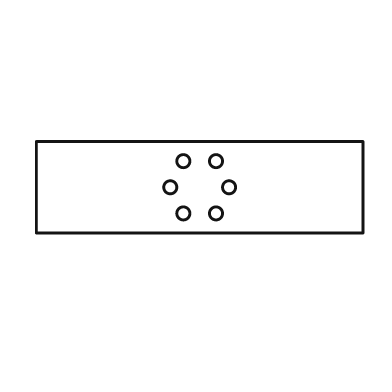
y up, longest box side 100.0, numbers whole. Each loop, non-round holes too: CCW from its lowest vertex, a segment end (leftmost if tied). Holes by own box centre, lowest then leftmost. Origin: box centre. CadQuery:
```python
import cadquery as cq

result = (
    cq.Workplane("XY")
    .moveTo(-50.0, -14.0)
    .lineTo(50.0, -14.0)
    .lineTo(50.0, 14.0)
    .lineTo(-50.0, 14.0)
    .close()
    .moveTo(-5.0, -8.0)
    .circle(2.0)
    .moveTo(5.0, -8.0)
    .circle(2.0)
    .moveTo(-9.0, 0.0)
    .circle(2.0)
    .moveTo(9.0, 0.0)
    .circle(2.0)
    .moveTo(-5.0, 8.0)
    .circle(2.0)
    .moveTo(5.0, 8.0)
    .circle(2.0)
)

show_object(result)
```